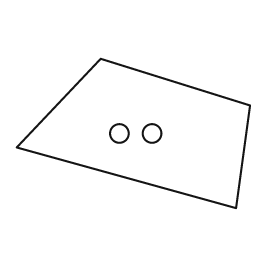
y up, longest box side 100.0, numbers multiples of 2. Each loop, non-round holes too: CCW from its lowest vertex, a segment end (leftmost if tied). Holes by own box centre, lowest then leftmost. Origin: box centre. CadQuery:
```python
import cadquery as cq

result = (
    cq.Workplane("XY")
    .moveTo(44.0, -32.0)
    .lineTo(50.0, 12.0)
    .lineTo(-14.0, 32.0)
    .lineTo(-50.0, -6.0)
    .close()
    .moveTo(-6.0, 0.0)
    .circle(4.0)
    .moveTo(8.0, 0.0)
    .circle(4.0)
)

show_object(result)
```